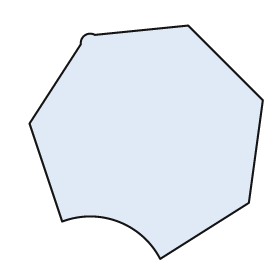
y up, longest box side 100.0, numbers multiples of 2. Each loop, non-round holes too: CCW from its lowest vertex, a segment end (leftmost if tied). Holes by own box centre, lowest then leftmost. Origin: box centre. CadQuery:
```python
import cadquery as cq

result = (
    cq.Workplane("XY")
    .moveTo(6.0, -50.0)
    .lineTo(44.0, -26.0)
    .lineTo(50.0, 18.0)
    .lineTo(18.0, 50.0)
    .lineTo(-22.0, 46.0)
    .threePointArc((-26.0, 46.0), (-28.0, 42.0))
    .lineTo(-50.0, 8.0)
    .lineTo(-36.0, -34.0)
    .threePointArc((-12.0, -34.0), (6.0, -50.0))
    .close()
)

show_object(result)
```